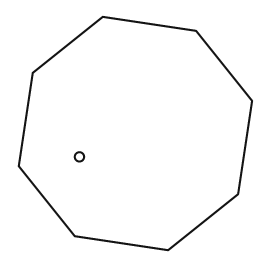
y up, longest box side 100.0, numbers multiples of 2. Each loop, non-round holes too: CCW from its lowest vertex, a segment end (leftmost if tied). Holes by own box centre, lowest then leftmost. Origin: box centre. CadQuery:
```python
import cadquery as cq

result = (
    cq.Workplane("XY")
    .moveTo(14.0, -50.0)
    .lineTo(44.0, -26.0)
    .lineTo(50.0, 14.0)
    .lineTo(26.0, 44.0)
    .lineTo(-14.0, 50.0)
    .lineTo(-44.0, 26.0)
    .lineTo(-50.0, -14.0)
    .lineTo(-26.0, -44.0)
    .close()
    .moveTo(-24.0, -10.0)
    .circle(2.0)
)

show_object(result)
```